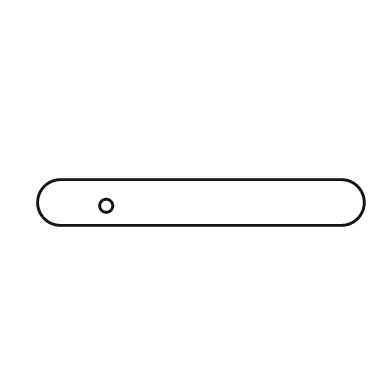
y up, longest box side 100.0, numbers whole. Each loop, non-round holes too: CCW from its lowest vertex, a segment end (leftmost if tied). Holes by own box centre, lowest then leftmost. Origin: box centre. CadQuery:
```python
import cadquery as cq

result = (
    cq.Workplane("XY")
    .moveTo(-43.0, -7.0)
    .lineTo(43.0, -7.0)
    .threePointArc((50.0, 0.0), (43.0, 7.0))
    .lineTo(-43.0, 7.0)
    .threePointArc((-50.0, 0.0), (-43.0, -7.0))
    .close()
    .moveTo(-29.0, -1.0)
    .circle(2.0)
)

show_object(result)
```